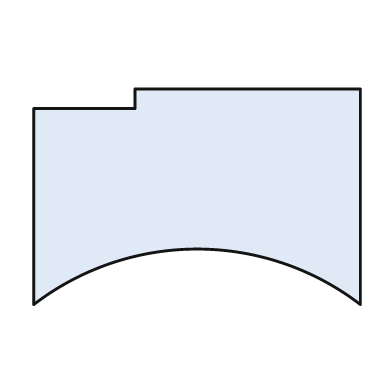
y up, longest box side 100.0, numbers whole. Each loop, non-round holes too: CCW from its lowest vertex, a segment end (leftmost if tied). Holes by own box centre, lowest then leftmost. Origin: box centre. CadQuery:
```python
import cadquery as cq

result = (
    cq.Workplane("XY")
    .moveTo(-50.0, -33.0)
    .threePointArc((0.0, -16.0), (50.0, -33.0))
    .lineTo(50.0, 33.0)
    .lineTo(-19.0, 33.0)
    .lineTo(-19.0, 27.0)
    .lineTo(-50.0, 27.0)
    .close()
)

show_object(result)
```